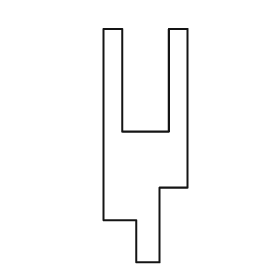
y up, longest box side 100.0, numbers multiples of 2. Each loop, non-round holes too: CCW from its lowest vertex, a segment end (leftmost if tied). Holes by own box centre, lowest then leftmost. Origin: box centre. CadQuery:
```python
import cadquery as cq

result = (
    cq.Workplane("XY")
    .moveTo(-4.0, -50.0)
    .lineTo(6.0, -50.0)
    .lineTo(6.0, -18.0)
    .lineTo(18.0, -18.0)
    .lineTo(18.0, 50.0)
    .lineTo(10.0, 50.0)
    .lineTo(10.0, 6.0)
    .lineTo(-10.0, 6.0)
    .lineTo(-10.0, 50.0)
    .lineTo(-18.0, 50.0)
    .lineTo(-18.0, -32.0)
    .lineTo(-4.0, -32.0)
    .close()
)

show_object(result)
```